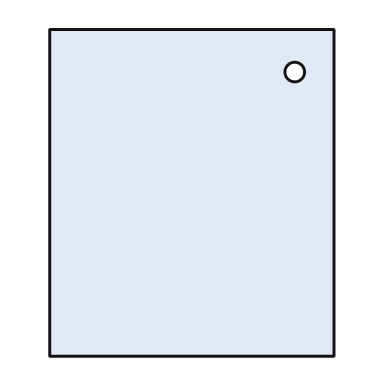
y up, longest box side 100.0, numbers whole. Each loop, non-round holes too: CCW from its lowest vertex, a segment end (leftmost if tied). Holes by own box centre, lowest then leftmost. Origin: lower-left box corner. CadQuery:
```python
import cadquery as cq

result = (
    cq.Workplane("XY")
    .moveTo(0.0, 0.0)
    .lineTo(87.0, 0.0)
    .lineTo(87.0, 100.0)
    .lineTo(0.0, 100.0)
    .close()
    .moveTo(75.0, 87.0)
    .circle(3.0)
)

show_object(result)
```